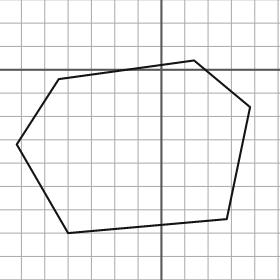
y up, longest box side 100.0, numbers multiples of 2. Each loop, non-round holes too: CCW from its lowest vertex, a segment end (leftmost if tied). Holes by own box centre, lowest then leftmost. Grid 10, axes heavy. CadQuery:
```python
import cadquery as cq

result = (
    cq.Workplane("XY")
    .moveTo(-40.0, -70.0)
    .lineTo(28.0, -64.0)
    .lineTo(38.0, -16.0)
    .lineTo(14.0, 4.0)
    .lineTo(-44.0, -4.0)
    .lineTo(-62.0, -32.0)
    .close()
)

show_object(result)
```